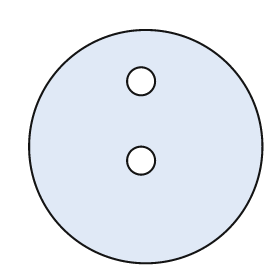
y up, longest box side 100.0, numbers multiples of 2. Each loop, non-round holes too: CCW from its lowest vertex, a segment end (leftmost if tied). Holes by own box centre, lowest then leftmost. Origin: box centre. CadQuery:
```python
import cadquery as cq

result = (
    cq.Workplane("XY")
    .moveTo(0.0, 0.0)
    .circle(50.0)
    .moveTo(-2.0, -6.0)
    .circle(6.0)
    .moveTo(-2.0, 28.0)
    .circle(6.0)
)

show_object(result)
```